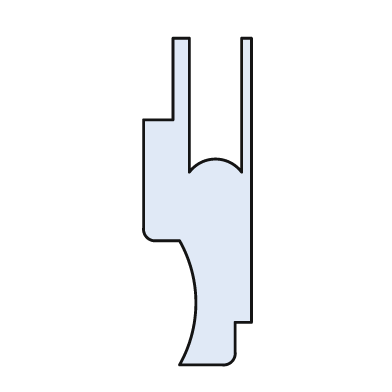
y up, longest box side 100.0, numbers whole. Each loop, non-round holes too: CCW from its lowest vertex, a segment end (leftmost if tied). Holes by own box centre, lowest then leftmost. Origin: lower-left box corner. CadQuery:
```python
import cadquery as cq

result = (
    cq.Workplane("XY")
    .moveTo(11.0, 0.0)
    .lineTo(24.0, 0.0)
    .threePointArc((27.0, 1.0), (28.0, 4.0))
    .lineTo(28.0, 13.0)
    .lineTo(33.0, 13.0)
    .lineTo(33.0, 100.0)
    .lineTo(30.0, 100.0)
    .lineTo(30.0, 59.0)
    .threePointArc((22.0, 63.0), (14.0, 59.0))
    .lineTo(14.0, 100.0)
    .lineTo(9.0, 100.0)
    .lineTo(9.0, 75.0)
    .lineTo(0.0, 75.0)
    .lineTo(0.0, 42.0)
    .threePointArc((1.0, 39.0), (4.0, 38.0))
    .lineTo(11.0, 38.0)
    .threePointArc((16.0, 19.0), (11.0, 0.0))
    .close()
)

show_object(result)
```